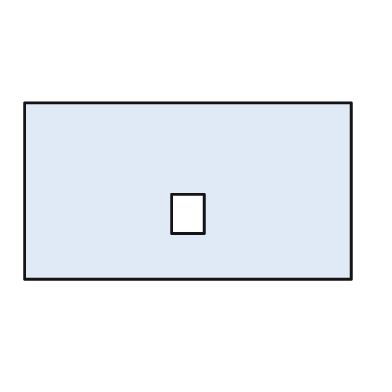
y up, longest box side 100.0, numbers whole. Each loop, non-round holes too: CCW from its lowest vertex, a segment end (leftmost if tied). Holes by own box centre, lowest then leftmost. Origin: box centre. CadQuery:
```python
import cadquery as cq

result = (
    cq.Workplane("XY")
    .moveTo(-50.0, -27.0)
    .lineTo(50.0, -27.0)
    .lineTo(50.0, 27.0)
    .lineTo(-50.0, 27.0)
    .close()
    .moveTo(-5.0, -13.0)
    .lineTo(5.0, -13.0)
    .lineTo(5.0, -1.0)
    .lineTo(-5.0, -1.0)
    .close()
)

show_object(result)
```